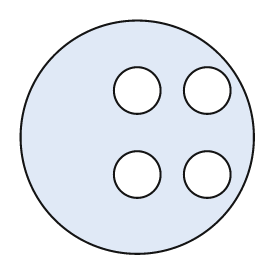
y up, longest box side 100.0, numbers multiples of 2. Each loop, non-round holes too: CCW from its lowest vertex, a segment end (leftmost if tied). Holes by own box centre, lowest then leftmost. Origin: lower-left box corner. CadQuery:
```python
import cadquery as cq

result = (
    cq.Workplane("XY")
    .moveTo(50.0, 50.0)
    .circle(50.0)
    .moveTo(50.0, 34.0)
    .circle(10.0)
    .moveTo(80.0, 34.0)
    .circle(10.0)
    .moveTo(50.0, 70.0)
    .circle(10.0)
    .moveTo(80.0, 70.0)
    .circle(10.0)
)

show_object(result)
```